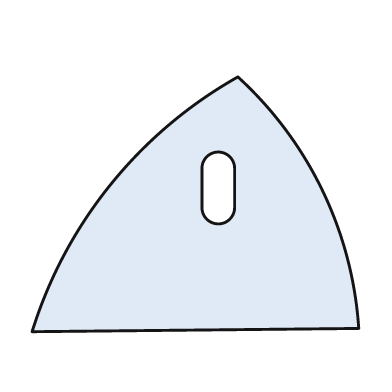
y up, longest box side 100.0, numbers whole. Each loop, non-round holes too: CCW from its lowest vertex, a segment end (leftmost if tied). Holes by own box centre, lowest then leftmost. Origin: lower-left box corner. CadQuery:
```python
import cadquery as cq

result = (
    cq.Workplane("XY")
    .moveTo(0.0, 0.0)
    .lineTo(100.0, 1.0)
    .threePointArc((89.0, 43.0), (63.0, 78.0))
    .threePointArc((24.0, 45.0), (0.0, 0.0))
    .close()
    .moveTo(52.0, 38.0)
    .threePointArc((57.0, 33.0), (62.0, 38.0))
    .lineTo(62.0, 50.0)
    .threePointArc((57.0, 55.0), (52.0, 50.0))
    .close()
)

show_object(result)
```